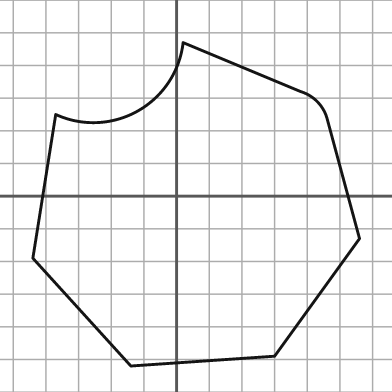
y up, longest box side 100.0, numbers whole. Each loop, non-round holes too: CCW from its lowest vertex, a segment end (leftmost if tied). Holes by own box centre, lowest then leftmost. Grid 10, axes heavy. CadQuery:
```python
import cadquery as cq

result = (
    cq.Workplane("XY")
    .moveTo(-14.0, -52.0)
    .lineTo(30.0, -49.0)
    .lineTo(56.0, -13.0)
    .lineTo(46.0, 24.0)
    .threePointArc((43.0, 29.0), (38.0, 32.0))
    .lineTo(2.0, 47.0)
    .threePointArc((-12.0, 26.0), (-37.0, 25.0))
    .lineTo(-44.0, -19.0)
    .close()
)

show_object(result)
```